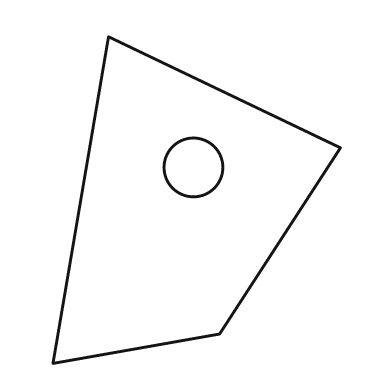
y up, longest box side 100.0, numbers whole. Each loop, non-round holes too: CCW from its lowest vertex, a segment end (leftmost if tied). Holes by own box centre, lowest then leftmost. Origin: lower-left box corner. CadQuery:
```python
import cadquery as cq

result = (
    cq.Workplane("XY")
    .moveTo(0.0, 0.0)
    .lineTo(51.0, 9.0)
    .lineTo(88.0, 66.0)
    .lineTo(17.0, 100.0)
    .close()
    .moveTo(43.0, 60.0)
    .circle(9.0)
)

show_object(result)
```